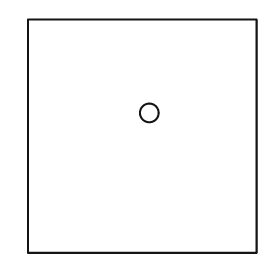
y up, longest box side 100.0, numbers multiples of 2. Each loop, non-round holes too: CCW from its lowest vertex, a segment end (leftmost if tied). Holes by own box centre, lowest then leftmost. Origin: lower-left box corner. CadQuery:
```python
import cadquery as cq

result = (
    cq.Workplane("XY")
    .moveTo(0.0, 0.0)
    .lineTo(98.0, 0.0)
    .lineTo(98.0, 100.0)
    .lineTo(0.0, 100.0)
    .close()
    .moveTo(52.0, 60.0)
    .circle(4.0)
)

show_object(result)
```